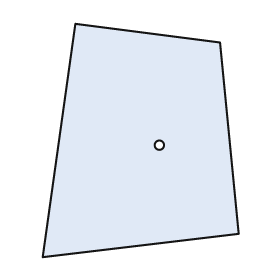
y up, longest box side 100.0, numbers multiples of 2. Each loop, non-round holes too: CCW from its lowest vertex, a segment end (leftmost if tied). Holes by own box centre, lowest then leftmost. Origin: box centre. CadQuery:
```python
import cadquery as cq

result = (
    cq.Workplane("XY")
    .moveTo(-42.0, -50.0)
    .lineTo(42.0, -40.0)
    .lineTo(34.0, 42.0)
    .lineTo(-28.0, 50.0)
    .close()
    .moveTo(8.0, -2.0)
    .circle(2.0)
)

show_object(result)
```